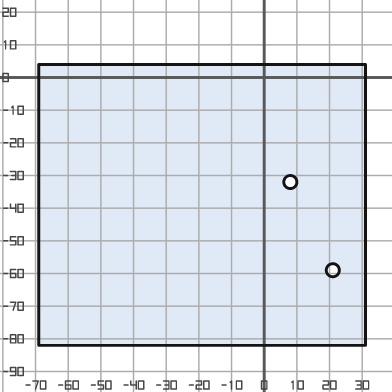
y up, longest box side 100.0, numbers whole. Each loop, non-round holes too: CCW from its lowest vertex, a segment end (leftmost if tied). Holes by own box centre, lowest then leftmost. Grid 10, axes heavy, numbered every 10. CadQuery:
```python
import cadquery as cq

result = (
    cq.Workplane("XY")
    .moveTo(-69.0, -82.0)
    .lineTo(31.0, -82.0)
    .lineTo(31.0, 4.0)
    .lineTo(-69.0, 4.0)
    .close()
    .moveTo(21.0, -59.0)
    .circle(2.0)
    .moveTo(8.0, -32.0)
    .circle(2.0)
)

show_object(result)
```